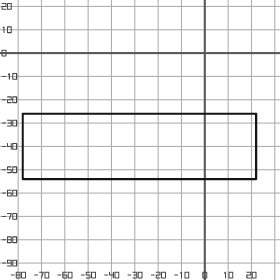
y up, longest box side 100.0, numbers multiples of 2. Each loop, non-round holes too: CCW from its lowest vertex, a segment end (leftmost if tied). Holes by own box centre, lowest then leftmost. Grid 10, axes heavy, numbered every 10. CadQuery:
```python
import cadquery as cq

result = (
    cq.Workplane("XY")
    .moveTo(-78.0, -54.0)
    .lineTo(22.0, -54.0)
    .lineTo(22.0, -26.0)
    .lineTo(-78.0, -26.0)
    .close()
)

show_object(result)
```